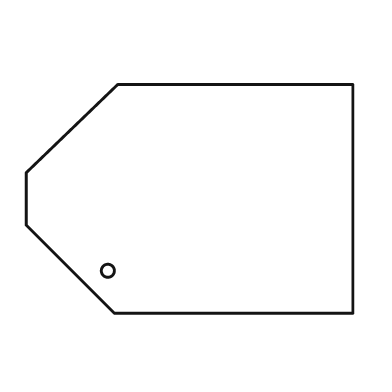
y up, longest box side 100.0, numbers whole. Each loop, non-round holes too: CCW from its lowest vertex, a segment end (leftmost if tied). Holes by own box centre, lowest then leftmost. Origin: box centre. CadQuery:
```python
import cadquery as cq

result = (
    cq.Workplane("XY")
    .moveTo(-23.0, -35.0)
    .lineTo(50.0, -35.0)
    .lineTo(50.0, 35.0)
    .lineTo(-22.0, 35.0)
    .lineTo(-50.0, 8.0)
    .lineTo(-50.0, -8.0)
    .close()
    .moveTo(-25.0, -22.0)
    .circle(2.0)
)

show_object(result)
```